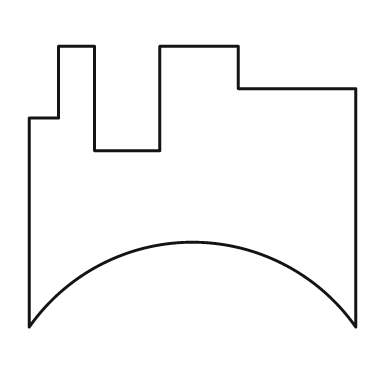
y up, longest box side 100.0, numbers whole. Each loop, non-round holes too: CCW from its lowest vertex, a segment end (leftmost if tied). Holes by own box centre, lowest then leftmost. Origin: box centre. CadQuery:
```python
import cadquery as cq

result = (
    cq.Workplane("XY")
    .moveTo(-50.0, -43.0)
    .threePointArc((0.0, -17.0), (50.0, -43.0))
    .lineTo(50.0, 30.0)
    .lineTo(14.0, 30.0)
    .lineTo(14.0, 43.0)
    .lineTo(-10.0, 43.0)
    .lineTo(-10.0, 11.0)
    .lineTo(-30.0, 11.0)
    .lineTo(-30.0, 43.0)
    .lineTo(-41.0, 43.0)
    .lineTo(-41.0, 21.0)
    .lineTo(-50.0, 21.0)
    .close()
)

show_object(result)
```